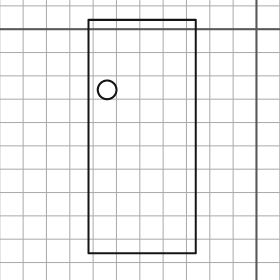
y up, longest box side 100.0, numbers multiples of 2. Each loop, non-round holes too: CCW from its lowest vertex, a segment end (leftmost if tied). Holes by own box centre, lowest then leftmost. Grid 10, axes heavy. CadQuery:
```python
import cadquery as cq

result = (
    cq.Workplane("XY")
    .moveTo(-72.0, -96.0)
    .lineTo(-26.0, -96.0)
    .lineTo(-26.0, 4.0)
    .lineTo(-72.0, 4.0)
    .close()
    .moveTo(-64.0, -26.0)
    .circle(4.0)
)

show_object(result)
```